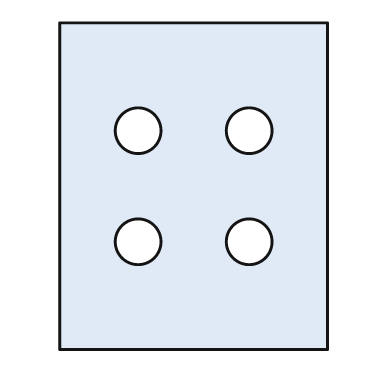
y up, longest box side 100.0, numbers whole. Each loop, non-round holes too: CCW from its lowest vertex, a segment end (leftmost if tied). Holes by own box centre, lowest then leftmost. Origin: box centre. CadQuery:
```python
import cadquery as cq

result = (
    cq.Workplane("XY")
    .moveTo(-41.0, -50.0)
    .lineTo(41.0, -50.0)
    .lineTo(41.0, 50.0)
    .lineTo(-41.0, 50.0)
    .close()
    .moveTo(-17.0, -17.0)
    .circle(7.0)
    .moveTo(17.0, -17.0)
    .circle(7.0)
    .moveTo(-17.0, 17.0)
    .circle(7.0)
    .moveTo(17.0, 17.0)
    .circle(7.0)
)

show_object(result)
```